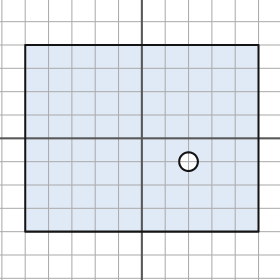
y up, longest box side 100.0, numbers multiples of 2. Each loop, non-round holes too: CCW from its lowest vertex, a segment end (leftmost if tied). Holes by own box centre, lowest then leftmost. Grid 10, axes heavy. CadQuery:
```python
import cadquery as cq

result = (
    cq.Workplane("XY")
    .moveTo(-50.0, -40.0)
    .lineTo(50.0, -40.0)
    .lineTo(50.0, 40.0)
    .lineTo(-50.0, 40.0)
    .close()
    .moveTo(20.0, -10.0)
    .circle(4.0)
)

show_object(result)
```